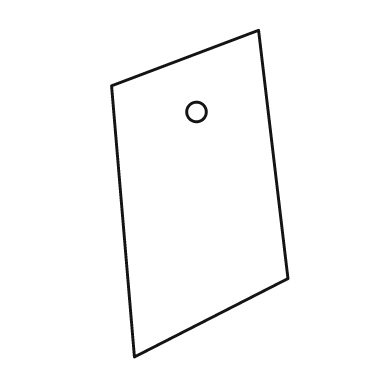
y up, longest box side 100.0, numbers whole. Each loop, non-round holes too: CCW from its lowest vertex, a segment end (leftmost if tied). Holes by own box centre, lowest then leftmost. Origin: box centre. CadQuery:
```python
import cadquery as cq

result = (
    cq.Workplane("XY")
    .moveTo(-20.0, -50.0)
    .lineTo(27.0, -26.0)
    .lineTo(18.0, 50.0)
    .lineTo(-27.0, 33.0)
    .close()
    .moveTo(-1.0, 25.0)
    .circle(3.0)
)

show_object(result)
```